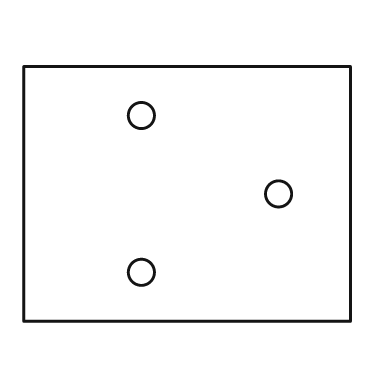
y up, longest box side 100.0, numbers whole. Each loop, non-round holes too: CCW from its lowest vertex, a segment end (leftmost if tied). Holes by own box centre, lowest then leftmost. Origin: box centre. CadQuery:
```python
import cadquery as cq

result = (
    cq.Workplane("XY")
    .moveTo(-50.0, -39.0)
    .lineTo(50.0, -39.0)
    .lineTo(50.0, 39.0)
    .lineTo(-50.0, 39.0)
    .close()
    .moveTo(-14.0, -24.0)
    .circle(4.0)
    .moveTo(28.0, 0.0)
    .circle(4.0)
    .moveTo(-14.0, 24.0)
    .circle(4.0)
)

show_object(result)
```